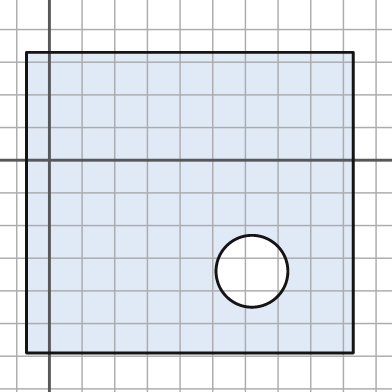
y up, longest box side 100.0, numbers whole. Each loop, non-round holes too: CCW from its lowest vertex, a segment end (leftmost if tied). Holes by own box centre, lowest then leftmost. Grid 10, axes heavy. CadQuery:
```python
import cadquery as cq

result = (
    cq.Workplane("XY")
    .moveTo(-7.0, -59.0)
    .lineTo(93.0, -59.0)
    .lineTo(93.0, 33.0)
    .lineTo(-7.0, 33.0)
    .close()
    .moveTo(62.0, -34.0)
    .circle(11.0)
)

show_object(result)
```